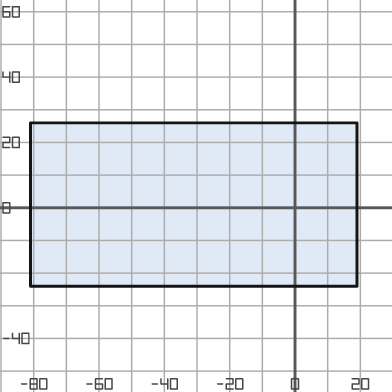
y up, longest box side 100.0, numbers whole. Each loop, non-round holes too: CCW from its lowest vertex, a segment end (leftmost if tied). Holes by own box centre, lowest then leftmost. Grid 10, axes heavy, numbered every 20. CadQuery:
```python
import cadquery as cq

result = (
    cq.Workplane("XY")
    .moveTo(-81.0, -24.0)
    .lineTo(19.0, -24.0)
    .lineTo(19.0, 26.0)
    .lineTo(-81.0, 26.0)
    .close()
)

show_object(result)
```